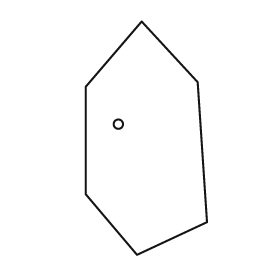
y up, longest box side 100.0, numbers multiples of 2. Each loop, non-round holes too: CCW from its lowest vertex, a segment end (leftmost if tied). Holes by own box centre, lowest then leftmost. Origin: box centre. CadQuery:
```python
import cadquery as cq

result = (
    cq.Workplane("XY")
    .moveTo(-4.0, -50.0)
    .lineTo(26.0, -36.0)
    .lineTo(22.0, 24.0)
    .lineTo(-2.0, 50.0)
    .lineTo(-26.0, 22.0)
    .lineTo(-26.0, -24.0)
    .close()
    .moveTo(-12.0, 6.0)
    .circle(2.0)
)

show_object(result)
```